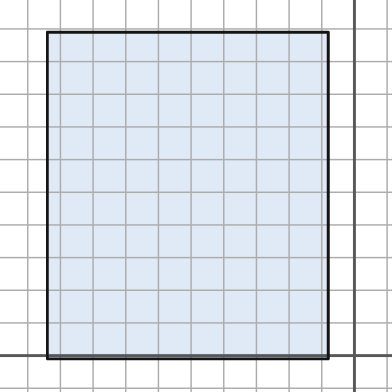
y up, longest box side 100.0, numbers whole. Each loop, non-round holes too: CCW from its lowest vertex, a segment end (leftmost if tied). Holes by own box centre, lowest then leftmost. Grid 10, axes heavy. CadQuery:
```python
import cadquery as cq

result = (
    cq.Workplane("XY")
    .moveTo(-94.0, -1.0)
    .lineTo(-8.0, -1.0)
    .lineTo(-8.0, 99.0)
    .lineTo(-94.0, 99.0)
    .close()
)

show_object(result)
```